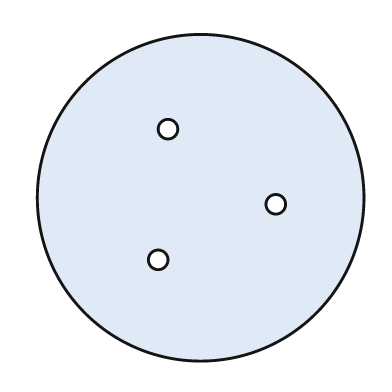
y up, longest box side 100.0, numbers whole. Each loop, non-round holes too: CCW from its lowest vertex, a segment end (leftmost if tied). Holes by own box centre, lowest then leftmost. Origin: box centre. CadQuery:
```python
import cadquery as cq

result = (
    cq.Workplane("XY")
    .moveTo(0.0, 0.0)
    .circle(50.0)
    .moveTo(-13.0, -19.0)
    .circle(3.0)
    .moveTo(23.0, -2.0)
    .circle(3.0)
    .moveTo(-10.0, 21.0)
    .circle(3.0)
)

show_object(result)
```